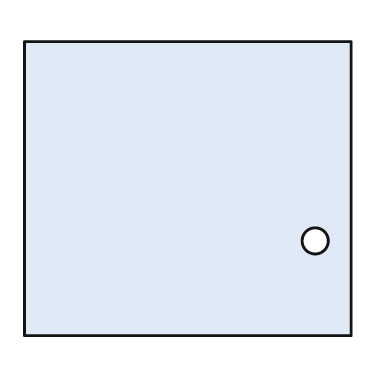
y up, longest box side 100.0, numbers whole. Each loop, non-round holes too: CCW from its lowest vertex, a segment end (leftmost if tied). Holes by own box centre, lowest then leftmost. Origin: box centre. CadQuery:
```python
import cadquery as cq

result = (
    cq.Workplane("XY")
    .moveTo(-50.0, -45.0)
    .lineTo(50.0, -45.0)
    .lineTo(50.0, 45.0)
    .lineTo(-50.0, 45.0)
    .close()
    .moveTo(39.0, -16.0)
    .circle(4.0)
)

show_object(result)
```